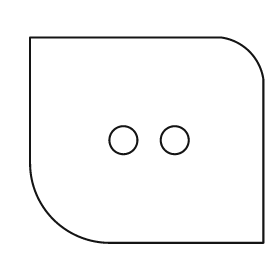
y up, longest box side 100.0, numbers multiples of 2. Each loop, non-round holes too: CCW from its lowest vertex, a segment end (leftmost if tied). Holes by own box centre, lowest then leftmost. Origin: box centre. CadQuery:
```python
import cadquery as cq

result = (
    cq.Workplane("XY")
    .moveTo(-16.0, -44.0)
    .lineTo(50.0, -44.0)
    .lineTo(50.0, 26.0)
    .threePointArc((44.0, 38.0), (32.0, 44.0))
    .lineTo(-50.0, 44.0)
    .lineTo(-50.0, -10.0)
    .threePointArc((-40.0, -34.0), (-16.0, -44.0))
    .close()
    .moveTo(-10.0, 0.0)
    .circle(6.0)
    .moveTo(12.0, 0.0)
    .circle(6.0)
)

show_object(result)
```